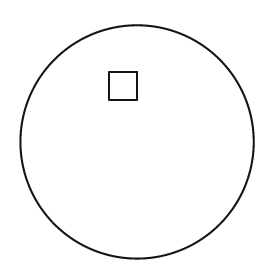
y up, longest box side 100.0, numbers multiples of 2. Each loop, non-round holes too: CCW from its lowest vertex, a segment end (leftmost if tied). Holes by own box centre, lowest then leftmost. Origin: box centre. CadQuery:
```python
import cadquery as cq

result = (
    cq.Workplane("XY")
    .moveTo(0.0, 0.0)
    .circle(50.0)
    .moveTo(-12.0, 18.0)
    .lineTo(0.0, 18.0)
    .lineTo(0.0, 30.0)
    .lineTo(-12.0, 30.0)
    .close()
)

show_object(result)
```